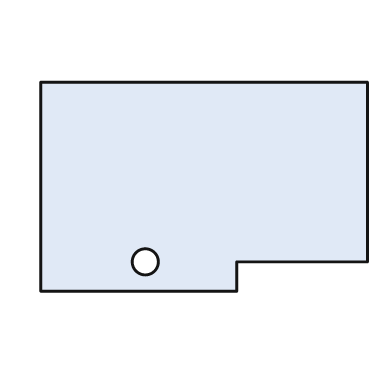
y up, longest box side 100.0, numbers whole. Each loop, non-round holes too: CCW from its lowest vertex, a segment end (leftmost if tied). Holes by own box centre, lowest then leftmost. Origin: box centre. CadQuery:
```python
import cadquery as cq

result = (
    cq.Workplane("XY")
    .moveTo(-50.0, -32.0)
    .lineTo(10.0, -32.0)
    .lineTo(10.0, -23.0)
    .lineTo(50.0, -23.0)
    .lineTo(50.0, 32.0)
    .lineTo(-50.0, 32.0)
    .close()
    .moveTo(-18.0, -23.0)
    .circle(4.0)
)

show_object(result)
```